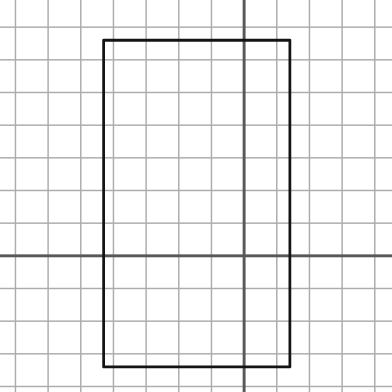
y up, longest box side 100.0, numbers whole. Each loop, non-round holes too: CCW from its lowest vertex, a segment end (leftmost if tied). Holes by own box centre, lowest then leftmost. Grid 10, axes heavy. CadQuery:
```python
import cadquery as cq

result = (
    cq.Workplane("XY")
    .moveTo(-43.0, -34.0)
    .lineTo(14.0, -34.0)
    .lineTo(14.0, 66.0)
    .lineTo(-43.0, 66.0)
    .close()
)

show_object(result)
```